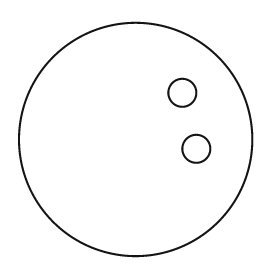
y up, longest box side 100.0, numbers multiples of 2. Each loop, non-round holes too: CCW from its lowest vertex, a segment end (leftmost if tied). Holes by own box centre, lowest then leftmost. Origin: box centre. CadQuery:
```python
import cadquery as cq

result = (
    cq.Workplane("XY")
    .moveTo(0.0, 0.0)
    .circle(50.0)
    .moveTo(26.0, -4.0)
    .circle(6.0)
    .moveTo(20.0, 20.0)
    .circle(6.0)
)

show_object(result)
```